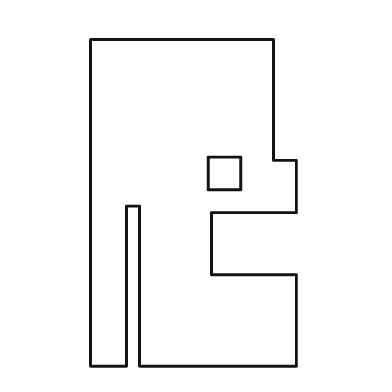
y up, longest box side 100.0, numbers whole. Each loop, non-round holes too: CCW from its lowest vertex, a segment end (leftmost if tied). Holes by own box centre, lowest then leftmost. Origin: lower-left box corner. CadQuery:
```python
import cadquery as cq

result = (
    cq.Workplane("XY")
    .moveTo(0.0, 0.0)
    .lineTo(11.0, 0.0)
    .lineTo(11.0, 49.0)
    .lineTo(15.0, 49.0)
    .lineTo(15.0, 0.0)
    .lineTo(63.0, 0.0)
    .lineTo(63.0, 28.0)
    .lineTo(37.0, 28.0)
    .lineTo(37.0, 47.0)
    .lineTo(63.0, 47.0)
    .lineTo(63.0, 63.0)
    .lineTo(56.0, 63.0)
    .lineTo(56.0, 100.0)
    .lineTo(0.0, 100.0)
    .close()
    .moveTo(36.0, 54.0)
    .lineTo(46.0, 54.0)
    .lineTo(46.0, 64.0)
    .lineTo(36.0, 64.0)
    .close()
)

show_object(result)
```